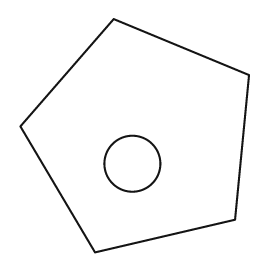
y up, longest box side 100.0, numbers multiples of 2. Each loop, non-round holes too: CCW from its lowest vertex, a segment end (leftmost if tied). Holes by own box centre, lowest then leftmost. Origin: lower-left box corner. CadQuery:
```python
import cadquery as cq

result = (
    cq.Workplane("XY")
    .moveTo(32.0, 0.0)
    .lineTo(92.0, 14.0)
    .lineTo(98.0, 76.0)
    .lineTo(40.0, 100.0)
    .lineTo(0.0, 54.0)
    .close()
    .moveTo(48.0, 38.0)
    .circle(12.0)
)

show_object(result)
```